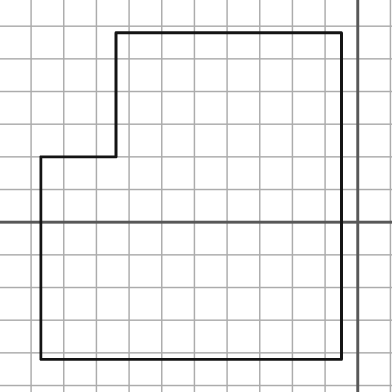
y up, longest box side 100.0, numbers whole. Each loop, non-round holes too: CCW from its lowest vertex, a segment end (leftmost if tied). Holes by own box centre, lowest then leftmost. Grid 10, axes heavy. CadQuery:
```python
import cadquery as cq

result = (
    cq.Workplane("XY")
    .moveTo(-97.0, -42.0)
    .lineTo(-5.0, -42.0)
    .lineTo(-5.0, 58.0)
    .lineTo(-74.0, 58.0)
    .lineTo(-74.0, 20.0)
    .lineTo(-97.0, 20.0)
    .close()
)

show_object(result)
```